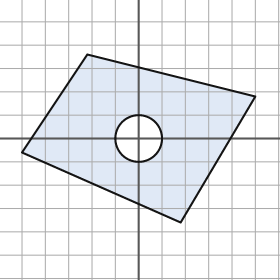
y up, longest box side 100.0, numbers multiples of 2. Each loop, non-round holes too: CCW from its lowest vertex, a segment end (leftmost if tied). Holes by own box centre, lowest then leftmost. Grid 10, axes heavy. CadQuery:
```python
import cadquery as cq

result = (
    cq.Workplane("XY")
    .moveTo(18.0, -36.0)
    .lineTo(50.0, 18.0)
    .lineTo(-22.0, 36.0)
    .lineTo(-50.0, -6.0)
    .close()
    .moveTo(0.0, 0.0)
    .circle(10.0)
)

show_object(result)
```